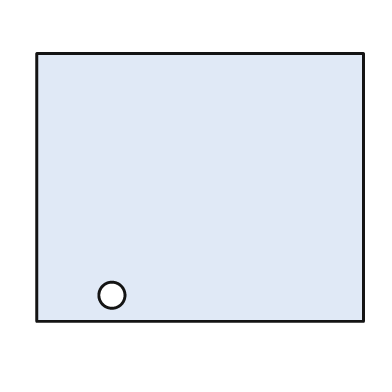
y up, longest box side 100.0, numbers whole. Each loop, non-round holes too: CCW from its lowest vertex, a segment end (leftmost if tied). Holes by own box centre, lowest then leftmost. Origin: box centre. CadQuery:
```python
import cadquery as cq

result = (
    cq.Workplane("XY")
    .moveTo(-50.0, -41.0)
    .lineTo(50.0, -41.0)
    .lineTo(50.0, 41.0)
    .lineTo(-50.0, 41.0)
    .close()
    .moveTo(-27.0, -33.0)
    .circle(4.0)
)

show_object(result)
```